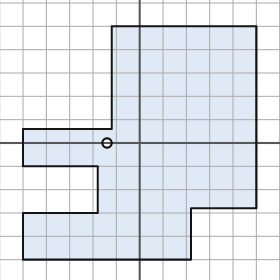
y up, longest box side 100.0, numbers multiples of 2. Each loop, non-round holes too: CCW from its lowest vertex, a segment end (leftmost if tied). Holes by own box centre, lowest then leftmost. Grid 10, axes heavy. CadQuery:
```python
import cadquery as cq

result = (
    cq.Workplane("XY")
    .moveTo(-50.0, -50.0)
    .lineTo(22.0, -50.0)
    .lineTo(22.0, -28.0)
    .lineTo(50.0, -28.0)
    .lineTo(50.0, 50.0)
    .lineTo(-12.0, 50.0)
    .lineTo(-12.0, 6.0)
    .lineTo(-50.0, 6.0)
    .lineTo(-50.0, -10.0)
    .lineTo(-18.0, -10.0)
    .lineTo(-18.0, -30.0)
    .lineTo(-50.0, -30.0)
    .close()
    .moveTo(-14.0, 0.0)
    .circle(2.0)
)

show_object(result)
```